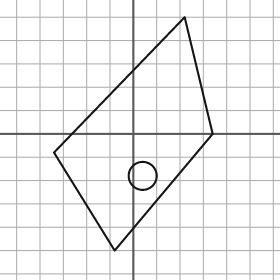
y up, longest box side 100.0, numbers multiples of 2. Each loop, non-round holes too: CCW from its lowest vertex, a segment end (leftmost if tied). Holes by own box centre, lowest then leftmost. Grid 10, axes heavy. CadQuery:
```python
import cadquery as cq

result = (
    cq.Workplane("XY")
    .moveTo(-8.0, -50.0)
    .lineTo(34.0, 0.0)
    .lineTo(22.0, 50.0)
    .lineTo(-34.0, -8.0)
    .close()
    .moveTo(4.0, -18.0)
    .circle(6.0)
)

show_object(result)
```